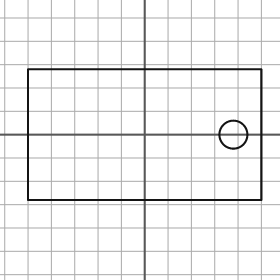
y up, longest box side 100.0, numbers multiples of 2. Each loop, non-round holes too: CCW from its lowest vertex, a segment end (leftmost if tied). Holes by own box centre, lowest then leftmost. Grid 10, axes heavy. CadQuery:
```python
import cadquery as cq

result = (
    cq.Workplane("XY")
    .moveTo(-50.0, -28.0)
    .lineTo(50.0, -28.0)
    .lineTo(50.0, 28.0)
    .lineTo(-50.0, 28.0)
    .close()
    .moveTo(38.0, 0.0)
    .circle(6.0)
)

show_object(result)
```